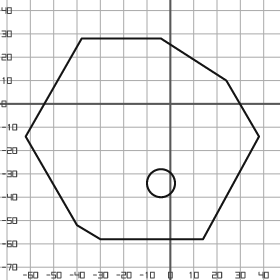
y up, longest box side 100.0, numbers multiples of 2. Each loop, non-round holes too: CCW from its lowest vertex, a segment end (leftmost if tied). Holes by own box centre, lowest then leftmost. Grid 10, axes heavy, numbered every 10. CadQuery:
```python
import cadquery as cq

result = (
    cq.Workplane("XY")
    .moveTo(-30.0, -58.0)
    .lineTo(14.0, -58.0)
    .lineTo(38.0, -14.0)
    .lineTo(24.0, 10.0)
    .lineTo(-4.0, 28.0)
    .lineTo(-38.0, 28.0)
    .lineTo(-62.0, -14.0)
    .lineTo(-40.0, -52.0)
    .close()
    .moveTo(-4.0, -34.0)
    .circle(6.0)
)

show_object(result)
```